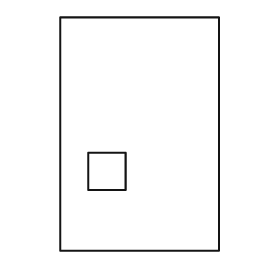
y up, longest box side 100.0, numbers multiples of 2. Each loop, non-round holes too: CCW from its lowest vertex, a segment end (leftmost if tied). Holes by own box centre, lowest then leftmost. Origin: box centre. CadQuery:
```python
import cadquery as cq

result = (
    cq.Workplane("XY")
    .moveTo(-34.0, -50.0)
    .lineTo(34.0, -50.0)
    .lineTo(34.0, 50.0)
    .lineTo(-34.0, 50.0)
    .close()
    .moveTo(-22.0, -24.0)
    .lineTo(-6.0, -24.0)
    .lineTo(-6.0, -8.0)
    .lineTo(-22.0, -8.0)
    .close()
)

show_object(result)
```